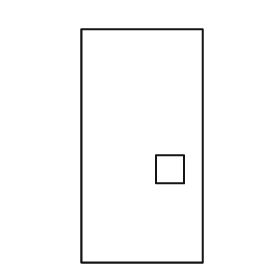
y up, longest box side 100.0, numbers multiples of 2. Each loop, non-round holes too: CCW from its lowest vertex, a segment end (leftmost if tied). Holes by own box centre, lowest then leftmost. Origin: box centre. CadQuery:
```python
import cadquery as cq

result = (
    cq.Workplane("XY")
    .moveTo(-26.0, -50.0)
    .lineTo(26.0, -50.0)
    .lineTo(26.0, 50.0)
    .lineTo(-26.0, 50.0)
    .close()
    .moveTo(6.0, -16.0)
    .lineTo(18.0, -16.0)
    .lineTo(18.0, -4.0)
    .lineTo(6.0, -4.0)
    .close()
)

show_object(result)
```